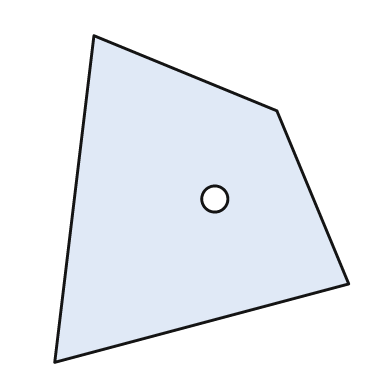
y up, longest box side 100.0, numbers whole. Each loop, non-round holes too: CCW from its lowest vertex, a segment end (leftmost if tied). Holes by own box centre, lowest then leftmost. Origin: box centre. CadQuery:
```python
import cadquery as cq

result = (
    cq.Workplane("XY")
    .moveTo(-45.0, -50.0)
    .lineTo(45.0, -26.0)
    .lineTo(23.0, 27.0)
    .lineTo(-33.0, 50.0)
    .close()
    .moveTo(4.0, 0.0)
    .circle(4.0)
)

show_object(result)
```